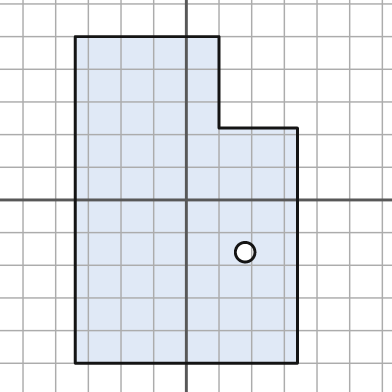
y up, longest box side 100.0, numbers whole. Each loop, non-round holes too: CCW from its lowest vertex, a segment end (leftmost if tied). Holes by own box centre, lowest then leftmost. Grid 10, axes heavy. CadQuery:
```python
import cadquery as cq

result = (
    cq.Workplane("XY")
    .moveTo(-34.0, -50.0)
    .lineTo(34.0, -50.0)
    .lineTo(34.0, 22.0)
    .lineTo(10.0, 22.0)
    .lineTo(10.0, 50.0)
    .lineTo(-34.0, 50.0)
    .close()
    .moveTo(18.0, -16.0)
    .circle(3.0)
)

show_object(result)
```